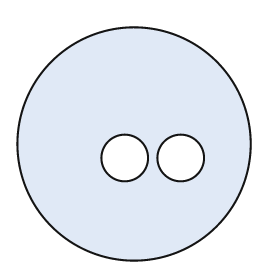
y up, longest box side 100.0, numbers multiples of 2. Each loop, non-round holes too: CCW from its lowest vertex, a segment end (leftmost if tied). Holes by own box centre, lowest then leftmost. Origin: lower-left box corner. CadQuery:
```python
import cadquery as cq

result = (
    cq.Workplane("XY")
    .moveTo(50.0, 50.0)
    .circle(50.0)
    .moveTo(46.0, 44.0)
    .circle(10.0)
    .moveTo(70.0, 44.0)
    .circle(10.0)
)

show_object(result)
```